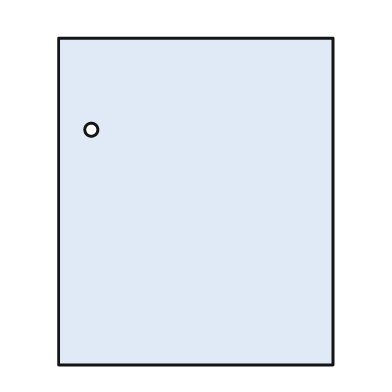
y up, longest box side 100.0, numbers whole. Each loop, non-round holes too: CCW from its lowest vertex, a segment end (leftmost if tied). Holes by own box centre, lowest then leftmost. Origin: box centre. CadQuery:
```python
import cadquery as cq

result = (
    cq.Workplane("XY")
    .moveTo(-42.0, -50.0)
    .lineTo(42.0, -50.0)
    .lineTo(42.0, 50.0)
    .lineTo(-42.0, 50.0)
    .close()
    .moveTo(-32.0, 22.0)
    .circle(2.0)
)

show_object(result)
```